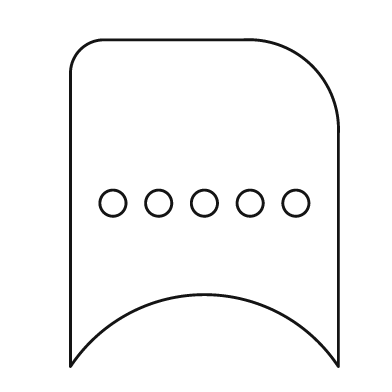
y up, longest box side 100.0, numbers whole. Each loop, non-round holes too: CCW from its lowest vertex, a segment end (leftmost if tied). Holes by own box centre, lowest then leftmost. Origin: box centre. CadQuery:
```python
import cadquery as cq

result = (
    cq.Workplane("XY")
    .moveTo(-41.0, -50.0)
    .threePointArc((0.0, -28.0), (41.0, -50.0))
    .lineTo(41.0, 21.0)
    .threePointArc((33.0, 42.0), (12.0, 50.0))
    .lineTo(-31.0, 50.0)
    .threePointArc((-38.0, 47.0), (-41.0, 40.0))
    .close()
    .moveTo(-28.0, 0.0)
    .circle(4.0)
    .moveTo(-14.0, 0.0)
    .circle(4.0)
    .moveTo(0.0, 0.0)
    .circle(4.0)
    .moveTo(14.0, 0.0)
    .circle(4.0)
    .moveTo(28.0, 0.0)
    .circle(4.0)
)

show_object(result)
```